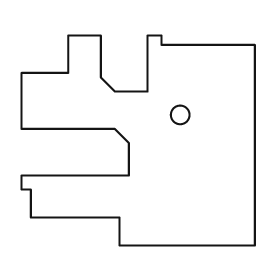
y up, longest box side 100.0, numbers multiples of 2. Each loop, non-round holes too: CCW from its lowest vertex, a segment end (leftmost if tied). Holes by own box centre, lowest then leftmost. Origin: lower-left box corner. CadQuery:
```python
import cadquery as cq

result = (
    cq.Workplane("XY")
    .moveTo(42.0, 0.0)
    .lineTo(100.0, 0.0)
    .lineTo(100.0, 86.0)
    .lineTo(60.0, 86.0)
    .lineTo(60.0, 90.0)
    .lineTo(54.0, 90.0)
    .lineTo(54.0, 66.0)
    .lineTo(40.0, 66.0)
    .lineTo(34.0, 72.0)
    .lineTo(34.0, 90.0)
    .lineTo(20.0, 90.0)
    .lineTo(20.0, 74.0)
    .lineTo(0.0, 74.0)
    .lineTo(0.0, 50.0)
    .lineTo(40.0, 50.0)
    .lineTo(46.0, 44.0)
    .lineTo(46.0, 30.0)
    .lineTo(0.0, 30.0)
    .lineTo(0.0, 24.0)
    .lineTo(4.0, 24.0)
    .lineTo(4.0, 12.0)
    .lineTo(42.0, 12.0)
    .close()
    .moveTo(68.0, 56.0)
    .circle(4.0)
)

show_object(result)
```